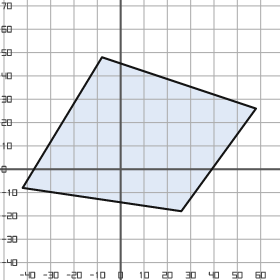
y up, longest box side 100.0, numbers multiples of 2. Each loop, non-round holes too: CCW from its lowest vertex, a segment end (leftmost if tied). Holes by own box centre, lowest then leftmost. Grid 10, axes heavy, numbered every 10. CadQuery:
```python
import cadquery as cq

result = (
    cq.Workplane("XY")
    .moveTo(26.0, -18.0)
    .lineTo(58.0, 26.0)
    .lineTo(-8.0, 48.0)
    .lineTo(-42.0, -8.0)
    .close()
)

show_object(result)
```